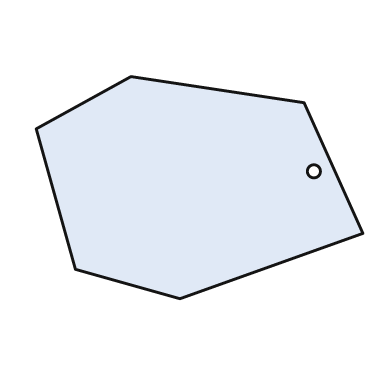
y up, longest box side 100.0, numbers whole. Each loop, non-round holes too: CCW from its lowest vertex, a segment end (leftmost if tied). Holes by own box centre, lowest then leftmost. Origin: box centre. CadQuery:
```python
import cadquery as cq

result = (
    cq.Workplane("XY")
    .moveTo(-6.0, -34.0)
    .lineTo(50.0, -14.0)
    .lineTo(32.0, 26.0)
    .lineTo(-21.0, 34.0)
    .lineTo(-50.0, 18.0)
    .lineTo(-38.0, -25.0)
    .close()
    .moveTo(35.0, 5.0)
    .circle(2.0)
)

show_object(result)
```